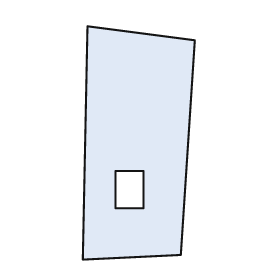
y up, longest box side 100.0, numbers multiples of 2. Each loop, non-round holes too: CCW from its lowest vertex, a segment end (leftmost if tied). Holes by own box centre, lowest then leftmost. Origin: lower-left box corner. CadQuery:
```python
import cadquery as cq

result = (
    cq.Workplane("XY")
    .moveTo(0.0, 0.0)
    .lineTo(42.0, 2.0)
    .lineTo(48.0, 94.0)
    .lineTo(2.0, 100.0)
    .close()
    .moveTo(14.0, 22.0)
    .lineTo(26.0, 22.0)
    .lineTo(26.0, 38.0)
    .lineTo(14.0, 38.0)
    .close()
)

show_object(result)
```